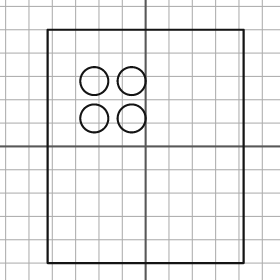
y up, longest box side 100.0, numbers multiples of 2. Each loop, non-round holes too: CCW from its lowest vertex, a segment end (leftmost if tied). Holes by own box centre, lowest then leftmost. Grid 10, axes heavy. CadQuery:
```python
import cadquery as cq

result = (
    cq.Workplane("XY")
    .moveTo(-42.0, -50.0)
    .lineTo(42.0, -50.0)
    .lineTo(42.0, 50.0)
    .lineTo(-42.0, 50.0)
    .close()
    .moveTo(-22.0, 12.0)
    .circle(6.0)
    .moveTo(-6.0, 12.0)
    .circle(6.0)
    .moveTo(-22.0, 28.0)
    .circle(6.0)
    .moveTo(-6.0, 28.0)
    .circle(6.0)
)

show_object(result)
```